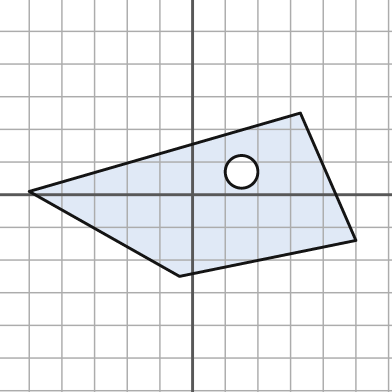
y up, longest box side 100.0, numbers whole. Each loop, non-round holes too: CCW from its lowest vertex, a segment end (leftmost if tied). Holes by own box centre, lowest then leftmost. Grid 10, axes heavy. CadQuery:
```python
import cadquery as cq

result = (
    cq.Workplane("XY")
    .moveTo(-4.0, -25.0)
    .lineTo(50.0, -14.0)
    .lineTo(33.0, 25.0)
    .lineTo(-50.0, 1.0)
    .close()
    .moveTo(15.0, 7.0)
    .circle(5.0)
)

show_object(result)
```